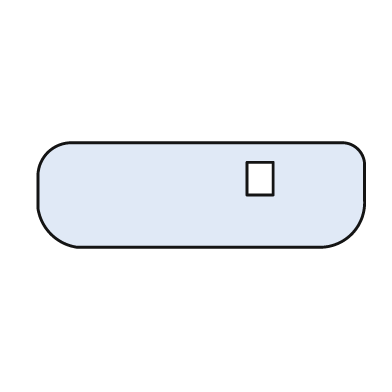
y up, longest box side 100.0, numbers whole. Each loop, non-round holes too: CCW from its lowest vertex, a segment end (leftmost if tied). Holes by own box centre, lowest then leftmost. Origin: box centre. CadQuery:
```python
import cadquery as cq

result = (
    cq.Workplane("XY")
    .moveTo(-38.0, -16.0)
    .lineTo(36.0, -16.0)
    .threePointArc((46.0, -12.0), (50.0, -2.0))
    .lineTo(50.0, 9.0)
    .threePointArc((48.0, 14.0), (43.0, 16.0))
    .lineTo(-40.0, 16.0)
    .threePointArc((-47.0, 13.0), (-50.0, 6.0))
    .lineTo(-50.0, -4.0)
    .threePointArc((-46.0, -12.0), (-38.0, -16.0))
    .close()
    .moveTo(14.0, 0.0)
    .lineTo(22.0, 0.0)
    .lineTo(22.0, 10.0)
    .lineTo(14.0, 10.0)
    .close()
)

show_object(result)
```